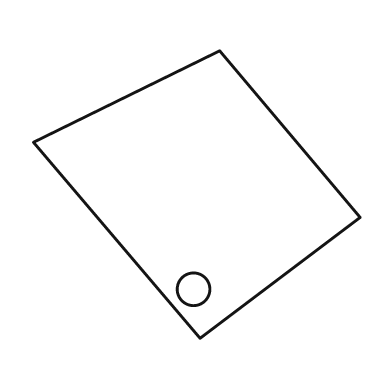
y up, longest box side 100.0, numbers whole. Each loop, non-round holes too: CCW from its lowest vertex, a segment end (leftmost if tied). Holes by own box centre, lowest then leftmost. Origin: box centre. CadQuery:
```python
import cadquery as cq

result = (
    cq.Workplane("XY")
    .moveTo(1.0, -44.0)
    .lineTo(50.0, -7.0)
    .lineTo(7.0, 44.0)
    .lineTo(-50.0, 16.0)
    .close()
    .moveTo(-1.0, -29.0)
    .circle(5.0)
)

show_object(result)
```